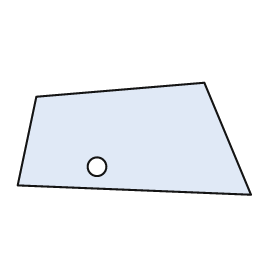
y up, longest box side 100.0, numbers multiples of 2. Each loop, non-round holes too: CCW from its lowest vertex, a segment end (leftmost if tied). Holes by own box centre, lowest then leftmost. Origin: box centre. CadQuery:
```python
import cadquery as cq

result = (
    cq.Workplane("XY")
    .moveTo(50.0, -24.0)
    .lineTo(30.0, 24.0)
    .lineTo(-42.0, 18.0)
    .lineTo(-50.0, -20.0)
    .close()
    .moveTo(-16.0, -12.0)
    .circle(4.0)
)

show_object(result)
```